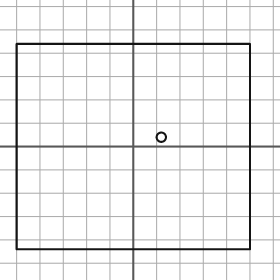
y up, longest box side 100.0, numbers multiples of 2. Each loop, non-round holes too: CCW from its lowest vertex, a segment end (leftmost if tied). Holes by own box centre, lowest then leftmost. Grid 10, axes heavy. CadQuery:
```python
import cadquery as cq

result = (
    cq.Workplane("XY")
    .moveTo(-50.0, -44.0)
    .lineTo(50.0, -44.0)
    .lineTo(50.0, 44.0)
    .lineTo(-50.0, 44.0)
    .close()
    .moveTo(12.0, 4.0)
    .circle(2.0)
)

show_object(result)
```